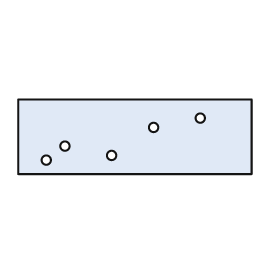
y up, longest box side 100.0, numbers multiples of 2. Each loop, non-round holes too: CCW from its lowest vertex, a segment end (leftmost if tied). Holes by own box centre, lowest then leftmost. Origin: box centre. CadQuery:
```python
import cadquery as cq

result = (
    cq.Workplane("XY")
    .moveTo(-50.0, -16.0)
    .lineTo(50.0, -16.0)
    .lineTo(50.0, 16.0)
    .lineTo(-50.0, 16.0)
    .close()
    .moveTo(-38.0, -10.0)
    .circle(2.0)
    .moveTo(-10.0, -8.0)
    .circle(2.0)
    .moveTo(-30.0, -4.0)
    .circle(2.0)
    .moveTo(8.0, 4.0)
    .circle(2.0)
    .moveTo(28.0, 8.0)
    .circle(2.0)
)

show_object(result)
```